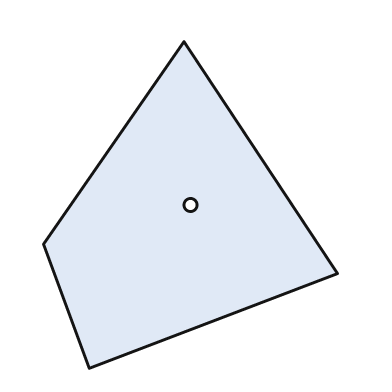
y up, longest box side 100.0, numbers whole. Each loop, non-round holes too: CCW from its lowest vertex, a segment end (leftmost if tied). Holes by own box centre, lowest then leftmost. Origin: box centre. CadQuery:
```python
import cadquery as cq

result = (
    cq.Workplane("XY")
    .moveTo(-31.0, -50.0)
    .lineTo(45.0, -21.0)
    .lineTo(-2.0, 50.0)
    .lineTo(-45.0, -12.0)
    .close()
    .moveTo(0.0, 0.0)
    .circle(2.0)
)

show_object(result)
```